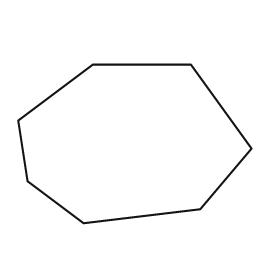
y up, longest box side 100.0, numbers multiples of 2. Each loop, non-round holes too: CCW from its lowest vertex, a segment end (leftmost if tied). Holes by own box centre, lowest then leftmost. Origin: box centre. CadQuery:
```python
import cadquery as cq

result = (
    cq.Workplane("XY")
    .moveTo(-22.0, -34.0)
    .lineTo(28.0, -28.0)
    .lineTo(50.0, -2.0)
    .lineTo(24.0, 34.0)
    .lineTo(-18.0, 34.0)
    .lineTo(-50.0, 10.0)
    .lineTo(-46.0, -16.0)
    .close()
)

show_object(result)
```